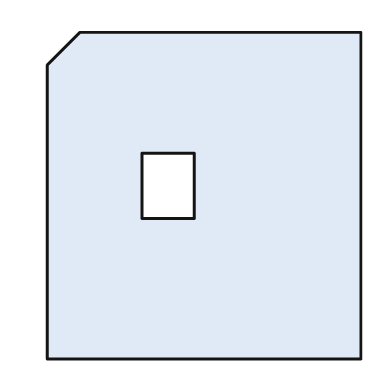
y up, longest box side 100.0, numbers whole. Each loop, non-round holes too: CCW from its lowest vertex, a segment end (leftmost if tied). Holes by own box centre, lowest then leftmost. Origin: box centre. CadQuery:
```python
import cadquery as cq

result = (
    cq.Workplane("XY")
    .moveTo(-48.0, -50.0)
    .lineTo(48.0, -50.0)
    .lineTo(48.0, 50.0)
    .lineTo(-38.0, 50.0)
    .lineTo(-48.0, 40.0)
    .close()
    .moveTo(-19.0, -7.0)
    .lineTo(-3.0, -7.0)
    .lineTo(-3.0, 13.0)
    .lineTo(-19.0, 13.0)
    .close()
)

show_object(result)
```